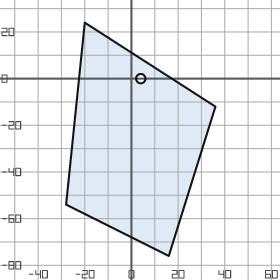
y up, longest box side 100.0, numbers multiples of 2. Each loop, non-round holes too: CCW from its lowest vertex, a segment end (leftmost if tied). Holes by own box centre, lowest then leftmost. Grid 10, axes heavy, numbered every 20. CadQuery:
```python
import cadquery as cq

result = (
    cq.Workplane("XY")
    .moveTo(16.0, -76.0)
    .lineTo(36.0, -12.0)
    .lineTo(-20.0, 24.0)
    .lineTo(-28.0, -54.0)
    .close()
    .moveTo(4.0, 0.0)
    .circle(2.0)
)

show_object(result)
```